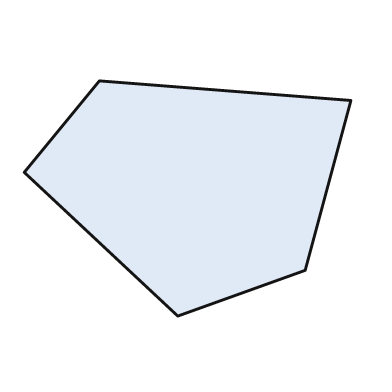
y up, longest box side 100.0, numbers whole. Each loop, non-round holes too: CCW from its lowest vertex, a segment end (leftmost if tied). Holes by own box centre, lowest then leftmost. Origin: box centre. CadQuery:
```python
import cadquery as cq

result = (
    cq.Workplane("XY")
    .moveTo(-3.0, -36.0)
    .lineTo(36.0, -22.0)
    .lineTo(50.0, 30.0)
    .lineTo(-27.0, 36.0)
    .lineTo(-50.0, 8.0)
    .close()
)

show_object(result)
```